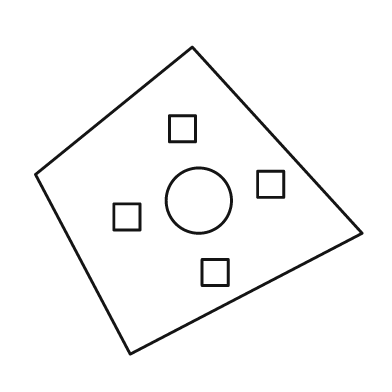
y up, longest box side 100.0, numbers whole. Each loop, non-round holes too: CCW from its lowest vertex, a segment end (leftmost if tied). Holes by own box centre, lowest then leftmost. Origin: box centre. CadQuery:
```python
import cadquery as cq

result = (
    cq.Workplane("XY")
    .moveTo(-21.0, -47.0)
    .lineTo(50.0, -10.0)
    .lineTo(-2.0, 47.0)
    .lineTo(-50.0, 8.0)
    .close()
    .moveTo(1.0, -26.0)
    .lineTo(9.0, -26.0)
    .lineTo(9.0, -18.0)
    .lineTo(1.0, -18.0)
    .close()
    .moveTo(-26.0, -9.0)
    .lineTo(-18.0, -9.0)
    .lineTo(-18.0, -1.0)
    .lineTo(-26.0, -1.0)
    .close()
    .moveTo(0.0, 0.0)
    .circle(10.0)
    .moveTo(18.0, 1.0)
    .lineTo(26.0, 1.0)
    .lineTo(26.0, 9.0)
    .lineTo(18.0, 9.0)
    .close()
    .moveTo(-9.0, 18.0)
    .lineTo(-1.0, 18.0)
    .lineTo(-1.0, 26.0)
    .lineTo(-9.0, 26.0)
    .close()
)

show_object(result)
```